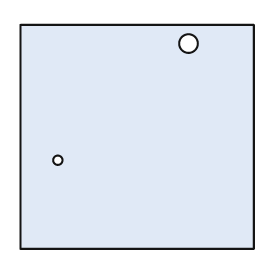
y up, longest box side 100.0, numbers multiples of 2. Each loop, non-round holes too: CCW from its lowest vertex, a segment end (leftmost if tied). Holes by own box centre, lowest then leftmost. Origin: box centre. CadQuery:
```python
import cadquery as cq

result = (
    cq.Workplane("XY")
    .moveTo(-50.0, -48.0)
    .lineTo(50.0, -48.0)
    .lineTo(50.0, 48.0)
    .lineTo(-50.0, 48.0)
    .close()
    .moveTo(-34.0, -10.0)
    .circle(2.0)
    .moveTo(22.0, 40.0)
    .circle(4.0)
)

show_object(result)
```